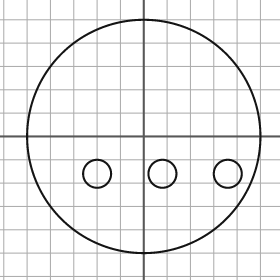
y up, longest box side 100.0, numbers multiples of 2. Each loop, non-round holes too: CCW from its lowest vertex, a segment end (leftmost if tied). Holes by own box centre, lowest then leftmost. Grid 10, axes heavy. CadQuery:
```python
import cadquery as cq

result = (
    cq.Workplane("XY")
    .moveTo(0.0, 0.0)
    .circle(50.0)
    .moveTo(-20.0, -16.0)
    .circle(6.0)
    .moveTo(8.0, -16.0)
    .circle(6.0)
    .moveTo(36.0, -16.0)
    .circle(6.0)
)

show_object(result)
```